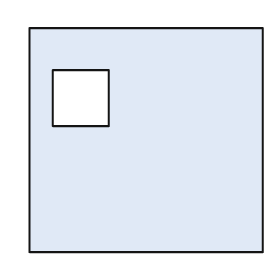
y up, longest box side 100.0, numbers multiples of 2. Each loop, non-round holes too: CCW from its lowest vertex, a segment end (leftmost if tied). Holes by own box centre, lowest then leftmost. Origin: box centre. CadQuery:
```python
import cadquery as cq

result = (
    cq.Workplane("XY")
    .moveTo(-50.0, -48.0)
    .lineTo(50.0, -48.0)
    .lineTo(50.0, 48.0)
    .lineTo(-50.0, 48.0)
    .close()
    .moveTo(-40.0, 6.0)
    .lineTo(-16.0, 6.0)
    .lineTo(-16.0, 30.0)
    .lineTo(-40.0, 30.0)
    .close()
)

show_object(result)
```